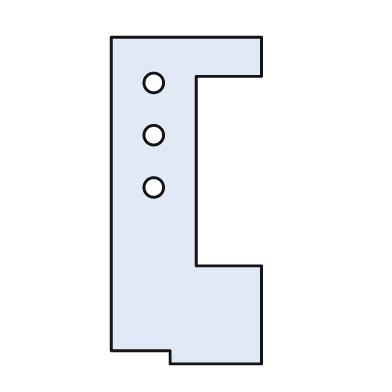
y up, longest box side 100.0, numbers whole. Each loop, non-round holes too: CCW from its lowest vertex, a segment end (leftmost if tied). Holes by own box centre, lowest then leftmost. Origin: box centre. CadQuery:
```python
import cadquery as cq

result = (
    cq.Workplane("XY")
    .moveTo(-5.0, -50.0)
    .lineTo(23.0, -50.0)
    .lineTo(23.0, -20.0)
    .lineTo(3.0, -20.0)
    .lineTo(3.0, 38.0)
    .lineTo(23.0, 38.0)
    .lineTo(23.0, 50.0)
    .lineTo(-23.0, 50.0)
    .lineTo(-23.0, -46.0)
    .lineTo(-5.0, -46.0)
    .close()
    .moveTo(-10.0, 4.0)
    .circle(3.0)
    .moveTo(-10.0, 20.0)
    .circle(3.0)
    .moveTo(-10.0, 36.0)
    .circle(3.0)
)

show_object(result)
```